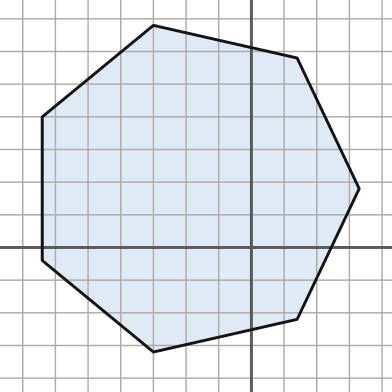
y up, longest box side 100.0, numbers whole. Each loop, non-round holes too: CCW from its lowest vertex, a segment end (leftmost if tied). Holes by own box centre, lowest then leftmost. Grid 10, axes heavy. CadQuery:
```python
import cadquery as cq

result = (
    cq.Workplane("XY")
    .moveTo(-30.0, -32.0)
    .lineTo(14.0, -22.0)
    .lineTo(33.0, 18.0)
    .lineTo(14.0, 58.0)
    .lineTo(-30.0, 68.0)
    .lineTo(-64.0, 40.0)
    .lineTo(-64.0, -4.0)
    .close()
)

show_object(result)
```